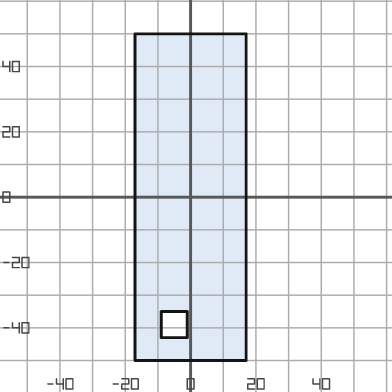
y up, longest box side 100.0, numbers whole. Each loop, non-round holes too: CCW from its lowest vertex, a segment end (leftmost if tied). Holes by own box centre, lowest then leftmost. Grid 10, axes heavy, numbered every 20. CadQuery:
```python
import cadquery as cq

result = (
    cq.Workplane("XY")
    .moveTo(-17.0, -50.0)
    .lineTo(17.0, -50.0)
    .lineTo(17.0, 50.0)
    .lineTo(-17.0, 50.0)
    .close()
    .moveTo(-9.0, -43.0)
    .lineTo(-1.0, -43.0)
    .lineTo(-1.0, -35.0)
    .lineTo(-9.0, -35.0)
    .close()
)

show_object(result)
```